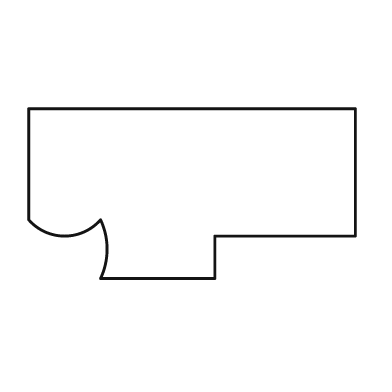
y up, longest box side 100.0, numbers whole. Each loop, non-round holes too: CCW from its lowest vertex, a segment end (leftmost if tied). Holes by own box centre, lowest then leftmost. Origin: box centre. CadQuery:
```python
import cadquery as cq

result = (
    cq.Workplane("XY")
    .moveTo(-28.0, -26.0)
    .lineTo(7.0, -26.0)
    .lineTo(7.0, -13.0)
    .lineTo(50.0, -13.0)
    .lineTo(50.0, 26.0)
    .lineTo(-50.0, 26.0)
    .lineTo(-50.0, -8.0)
    .threePointArc((-39.0, -13.0), (-28.0, -8.0))
    .threePointArc((-26.0, -17.0), (-28.0, -26.0))
    .close()
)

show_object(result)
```